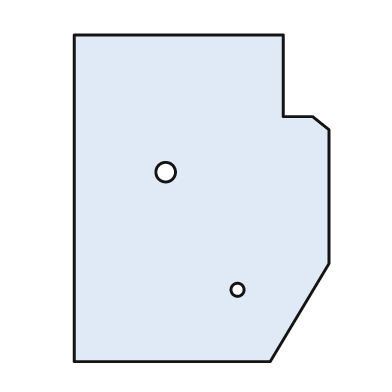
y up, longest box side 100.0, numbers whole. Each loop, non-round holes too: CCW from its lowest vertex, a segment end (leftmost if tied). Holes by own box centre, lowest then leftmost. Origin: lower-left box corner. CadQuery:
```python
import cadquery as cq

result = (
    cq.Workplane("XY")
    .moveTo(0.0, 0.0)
    .lineTo(60.0, 0.0)
    .lineTo(78.0, 30.0)
    .lineTo(78.0, 71.0)
    .lineTo(73.0, 75.0)
    .lineTo(64.0, 75.0)
    .lineTo(64.0, 100.0)
    .lineTo(0.0, 100.0)
    .close()
    .moveTo(50.0, 22.0)
    .circle(2.0)
    .moveTo(28.0, 58.0)
    .circle(3.0)
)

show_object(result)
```